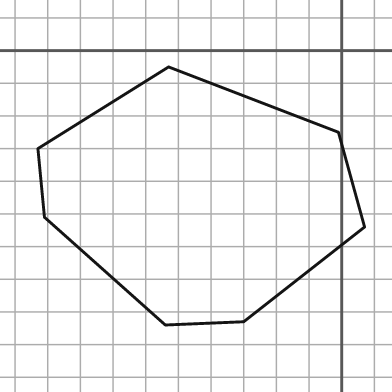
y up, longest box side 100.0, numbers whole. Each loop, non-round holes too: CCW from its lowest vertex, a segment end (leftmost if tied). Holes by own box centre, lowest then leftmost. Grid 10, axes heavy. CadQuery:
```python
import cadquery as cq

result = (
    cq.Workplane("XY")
    .moveTo(-54.0, -84.0)
    .lineTo(-30.0, -83.0)
    .lineTo(7.0, -54.0)
    .lineTo(-1.0, -25.0)
    .lineTo(-53.0, -5.0)
    .lineTo(-93.0, -30.0)
    .lineTo(-91.0, -51.0)
    .close()
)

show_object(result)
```